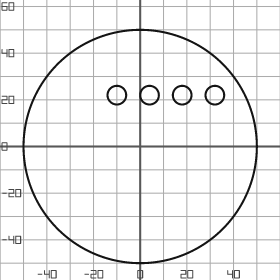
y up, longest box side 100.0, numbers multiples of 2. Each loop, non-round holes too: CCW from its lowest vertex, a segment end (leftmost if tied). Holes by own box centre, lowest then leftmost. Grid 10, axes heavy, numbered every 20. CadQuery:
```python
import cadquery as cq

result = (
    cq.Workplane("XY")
    .moveTo(0.0, 0.0)
    .circle(50.0)
    .moveTo(-10.0, 22.0)
    .circle(4.0)
    .moveTo(4.0, 22.0)
    .circle(4.0)
    .moveTo(18.0, 22.0)
    .circle(4.0)
    .moveTo(32.0, 22.0)
    .circle(4.0)
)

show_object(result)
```